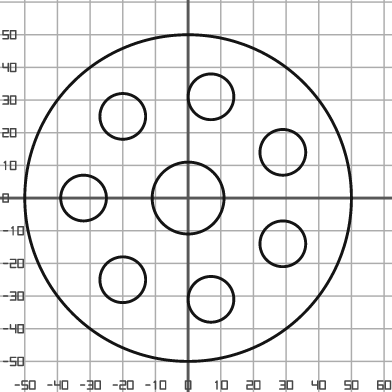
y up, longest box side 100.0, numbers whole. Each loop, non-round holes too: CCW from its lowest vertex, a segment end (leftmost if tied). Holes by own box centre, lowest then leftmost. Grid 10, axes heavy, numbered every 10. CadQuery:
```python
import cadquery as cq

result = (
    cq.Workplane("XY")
    .moveTo(0.0, 0.0)
    .circle(50.0)
    .moveTo(7.0, -31.0)
    .circle(7.0)
    .moveTo(-20.0, -25.0)
    .circle(7.0)
    .moveTo(29.0, -14.0)
    .circle(7.0)
    .moveTo(-32.0, 0.0)
    .circle(7.0)
    .moveTo(0.0, 0.0)
    .circle(11.0)
    .moveTo(29.0, 14.0)
    .circle(7.0)
    .moveTo(-20.0, 25.0)
    .circle(7.0)
    .moveTo(7.0, 31.0)
    .circle(7.0)
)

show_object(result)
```